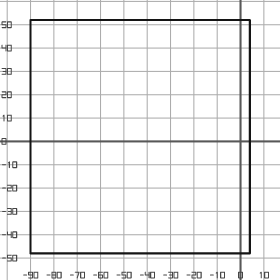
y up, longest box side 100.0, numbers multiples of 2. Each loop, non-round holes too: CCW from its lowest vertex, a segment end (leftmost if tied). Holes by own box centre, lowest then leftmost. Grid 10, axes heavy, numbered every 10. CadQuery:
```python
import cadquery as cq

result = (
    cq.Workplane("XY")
    .moveTo(-90.0, -48.0)
    .lineTo(4.0, -48.0)
    .lineTo(4.0, 52.0)
    .lineTo(-90.0, 52.0)
    .close()
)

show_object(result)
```